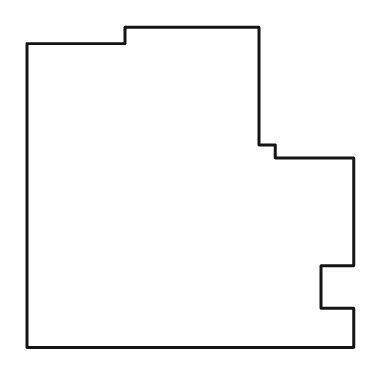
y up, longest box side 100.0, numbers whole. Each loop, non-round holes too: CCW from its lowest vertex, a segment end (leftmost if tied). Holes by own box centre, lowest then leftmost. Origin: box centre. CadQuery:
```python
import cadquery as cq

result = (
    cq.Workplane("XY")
    .moveTo(-50.0, -49.0)
    .lineTo(50.0, -49.0)
    .lineTo(50.0, -37.0)
    .lineTo(40.0, -37.0)
    .lineTo(40.0, -24.0)
    .lineTo(50.0, -24.0)
    .lineTo(50.0, 9.0)
    .lineTo(26.0, 9.0)
    .lineTo(26.0, 13.0)
    .lineTo(21.0, 13.0)
    .lineTo(21.0, 49.0)
    .lineTo(-20.0, 49.0)
    .lineTo(-20.0, 44.0)
    .lineTo(-50.0, 44.0)
    .close()
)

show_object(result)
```